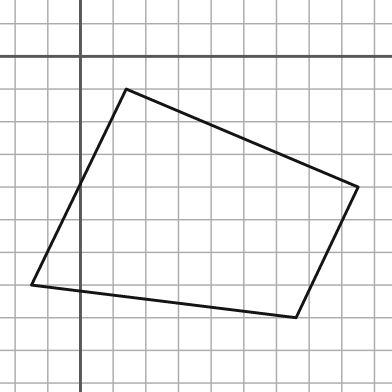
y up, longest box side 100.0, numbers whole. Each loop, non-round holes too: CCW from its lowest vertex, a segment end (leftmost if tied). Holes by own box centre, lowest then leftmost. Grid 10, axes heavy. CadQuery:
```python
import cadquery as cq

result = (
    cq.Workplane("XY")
    .moveTo(66.0, -80.0)
    .lineTo(85.0, -40.0)
    .lineTo(14.0, -10.0)
    .lineTo(-15.0, -70.0)
    .close()
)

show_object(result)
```